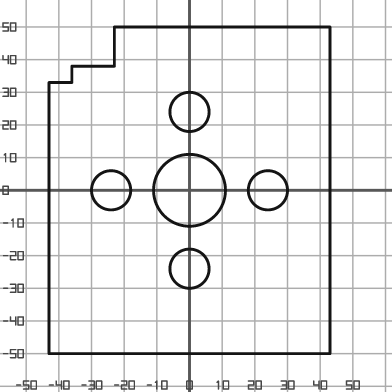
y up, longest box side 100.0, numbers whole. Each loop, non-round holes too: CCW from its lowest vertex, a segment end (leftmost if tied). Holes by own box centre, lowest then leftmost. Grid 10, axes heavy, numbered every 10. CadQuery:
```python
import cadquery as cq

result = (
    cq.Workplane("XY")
    .moveTo(-43.0, -50.0)
    .lineTo(43.0, -50.0)
    .lineTo(43.0, 50.0)
    .lineTo(-23.0, 50.0)
    .lineTo(-23.0, 38.0)
    .lineTo(-36.0, 38.0)
    .lineTo(-36.0, 33.0)
    .lineTo(-43.0, 33.0)
    .close()
    .moveTo(0.0, -24.0)
    .circle(6.0)
    .moveTo(-24.0, 0.0)
    .circle(6.0)
    .moveTo(0.0, 0.0)
    .circle(11.0)
    .moveTo(24.0, 0.0)
    .circle(6.0)
    .moveTo(0.0, 24.0)
    .circle(6.0)
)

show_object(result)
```